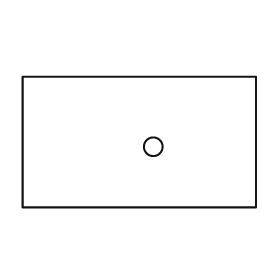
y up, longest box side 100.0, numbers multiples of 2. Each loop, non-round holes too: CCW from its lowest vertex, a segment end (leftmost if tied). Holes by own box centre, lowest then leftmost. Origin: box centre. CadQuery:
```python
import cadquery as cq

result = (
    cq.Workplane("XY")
    .moveTo(-50.0, -28.0)
    .lineTo(50.0, -28.0)
    .lineTo(50.0, 28.0)
    .lineTo(-50.0, 28.0)
    .close()
    .moveTo(6.0, -2.0)
    .circle(4.0)
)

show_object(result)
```